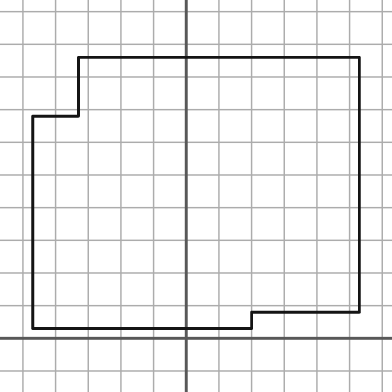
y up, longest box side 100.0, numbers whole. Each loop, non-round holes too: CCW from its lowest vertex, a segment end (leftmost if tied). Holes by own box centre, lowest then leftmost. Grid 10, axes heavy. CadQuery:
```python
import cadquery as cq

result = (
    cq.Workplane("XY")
    .moveTo(-47.0, 3.0)
    .lineTo(20.0, 3.0)
    .lineTo(20.0, 8.0)
    .lineTo(53.0, 8.0)
    .lineTo(53.0, 86.0)
    .lineTo(-33.0, 86.0)
    .lineTo(-33.0, 68.0)
    .lineTo(-47.0, 68.0)
    .close()
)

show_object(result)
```